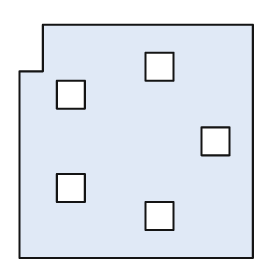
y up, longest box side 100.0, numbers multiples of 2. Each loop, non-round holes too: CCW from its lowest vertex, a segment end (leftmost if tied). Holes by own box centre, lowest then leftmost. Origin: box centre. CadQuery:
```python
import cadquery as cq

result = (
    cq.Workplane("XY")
    .moveTo(-50.0, -50.0)
    .lineTo(50.0, -50.0)
    .lineTo(50.0, 50.0)
    .lineTo(-40.0, 50.0)
    .lineTo(-40.0, 30.0)
    .lineTo(-50.0, 30.0)
    .close()
    .moveTo(4.0, -38.0)
    .lineTo(16.0, -38.0)
    .lineTo(16.0, -26.0)
    .lineTo(4.0, -26.0)
    .close()
    .moveTo(-34.0, -26.0)
    .lineTo(-22.0, -26.0)
    .lineTo(-22.0, -14.0)
    .lineTo(-34.0, -14.0)
    .close()
    .moveTo(28.0, -6.0)
    .lineTo(40.0, -6.0)
    .lineTo(40.0, 6.0)
    .lineTo(28.0, 6.0)
    .close()
    .moveTo(-34.0, 14.0)
    .lineTo(-22.0, 14.0)
    .lineTo(-22.0, 26.0)
    .lineTo(-34.0, 26.0)
    .close()
    .moveTo(4.0, 26.0)
    .lineTo(16.0, 26.0)
    .lineTo(16.0, 38.0)
    .lineTo(4.0, 38.0)
    .close()
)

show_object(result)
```